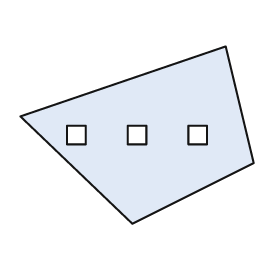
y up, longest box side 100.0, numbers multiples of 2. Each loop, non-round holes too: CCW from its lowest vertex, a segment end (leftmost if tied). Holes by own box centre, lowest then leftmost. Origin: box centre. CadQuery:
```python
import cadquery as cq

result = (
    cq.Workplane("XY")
    .moveTo(-2.0, -38.0)
    .lineTo(50.0, -12.0)
    .lineTo(38.0, 38.0)
    .lineTo(-50.0, 8.0)
    .close()
    .moveTo(-30.0, -4.0)
    .lineTo(-22.0, -4.0)
    .lineTo(-22.0, 4.0)
    .lineTo(-30.0, 4.0)
    .close()
    .moveTo(-4.0, -4.0)
    .lineTo(4.0, -4.0)
    .lineTo(4.0, 4.0)
    .lineTo(-4.0, 4.0)
    .close()
    .moveTo(22.0, -4.0)
    .lineTo(30.0, -4.0)
    .lineTo(30.0, 4.0)
    .lineTo(22.0, 4.0)
    .close()
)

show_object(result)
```